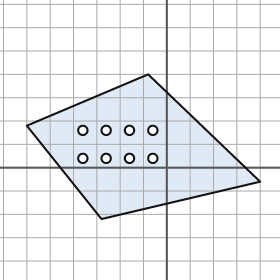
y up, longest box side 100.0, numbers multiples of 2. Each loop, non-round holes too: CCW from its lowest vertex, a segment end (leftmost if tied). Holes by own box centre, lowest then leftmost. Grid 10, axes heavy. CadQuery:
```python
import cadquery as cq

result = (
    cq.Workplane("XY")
    .moveTo(-28.0, -22.0)
    .lineTo(40.0, -6.0)
    .lineTo(-8.0, 40.0)
    .lineTo(-60.0, 18.0)
    .close()
    .moveTo(-36.0, 4.0)
    .circle(2.0)
    .moveTo(-26.0, 4.0)
    .circle(2.0)
    .moveTo(-16.0, 4.0)
    .circle(2.0)
    .moveTo(-6.0, 4.0)
    .circle(2.0)
    .moveTo(-36.0, 16.0)
    .circle(2.0)
    .moveTo(-26.0, 16.0)
    .circle(2.0)
    .moveTo(-16.0, 16.0)
    .circle(2.0)
    .moveTo(-6.0, 16.0)
    .circle(2.0)
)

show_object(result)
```